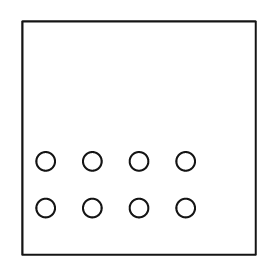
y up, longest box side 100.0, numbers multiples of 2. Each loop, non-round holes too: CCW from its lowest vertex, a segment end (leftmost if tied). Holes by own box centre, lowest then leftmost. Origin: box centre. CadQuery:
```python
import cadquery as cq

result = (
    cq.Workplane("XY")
    .moveTo(-50.0, -50.0)
    .lineTo(50.0, -50.0)
    .lineTo(50.0, 50.0)
    .lineTo(-50.0, 50.0)
    .close()
    .moveTo(-40.0, -30.0)
    .circle(4.0)
    .moveTo(-20.0, -30.0)
    .circle(4.0)
    .moveTo(0.0, -30.0)
    .circle(4.0)
    .moveTo(20.0, -30.0)
    .circle(4.0)
    .moveTo(-40.0, -10.0)
    .circle(4.0)
    .moveTo(-20.0, -10.0)
    .circle(4.0)
    .moveTo(0.0, -10.0)
    .circle(4.0)
    .moveTo(20.0, -10.0)
    .circle(4.0)
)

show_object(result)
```